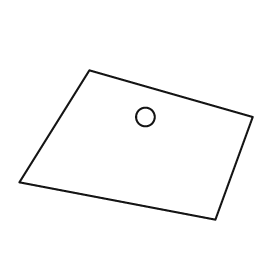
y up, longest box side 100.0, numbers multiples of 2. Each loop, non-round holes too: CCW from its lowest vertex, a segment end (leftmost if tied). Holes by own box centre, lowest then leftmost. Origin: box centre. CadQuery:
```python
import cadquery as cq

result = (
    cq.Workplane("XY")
    .moveTo(34.0, -32.0)
    .lineTo(50.0, 12.0)
    .lineTo(-20.0, 32.0)
    .lineTo(-50.0, -16.0)
    .close()
    .moveTo(4.0, 12.0)
    .circle(4.0)
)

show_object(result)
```